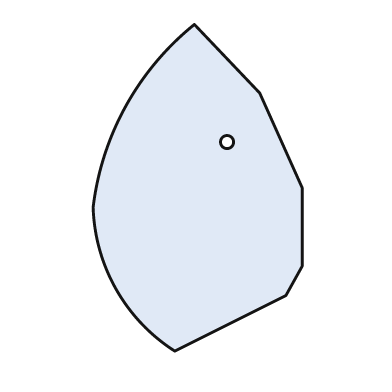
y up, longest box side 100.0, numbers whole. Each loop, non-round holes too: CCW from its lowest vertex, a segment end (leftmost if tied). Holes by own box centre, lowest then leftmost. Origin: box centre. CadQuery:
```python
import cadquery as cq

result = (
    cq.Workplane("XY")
    .moveTo(-7.0, -50.0)
    .lineTo(27.0, -33.0)
    .lineTo(32.0, -24.0)
    .lineTo(32.0, 0.0)
    .lineTo(19.0, 29.0)
    .lineTo(-1.0, 50.0)
    .threePointArc((-22.0, 25.0), (-32.0, -6.0))
    .threePointArc((-25.0, -31.0), (-7.0, -50.0))
    .close()
    .moveTo(9.0, 14.0)
    .circle(2.0)
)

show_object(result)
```